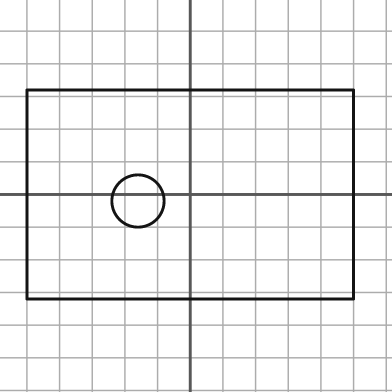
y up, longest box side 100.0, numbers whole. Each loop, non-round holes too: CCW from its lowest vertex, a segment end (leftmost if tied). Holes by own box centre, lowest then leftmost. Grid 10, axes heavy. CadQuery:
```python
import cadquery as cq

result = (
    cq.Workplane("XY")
    .moveTo(-50.0, -32.0)
    .lineTo(50.0, -32.0)
    .lineTo(50.0, 32.0)
    .lineTo(-50.0, 32.0)
    .close()
    .moveTo(-16.0, -2.0)
    .circle(8.0)
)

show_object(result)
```